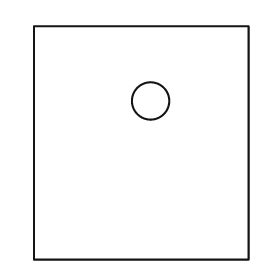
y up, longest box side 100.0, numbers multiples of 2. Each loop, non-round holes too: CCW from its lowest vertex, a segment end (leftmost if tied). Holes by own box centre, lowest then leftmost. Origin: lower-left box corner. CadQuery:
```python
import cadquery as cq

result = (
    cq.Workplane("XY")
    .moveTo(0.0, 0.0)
    .lineTo(92.0, 0.0)
    .lineTo(92.0, 100.0)
    .lineTo(0.0, 100.0)
    .close()
    .moveTo(50.0, 68.0)
    .circle(8.0)
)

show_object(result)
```